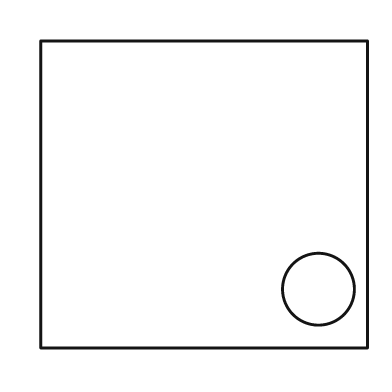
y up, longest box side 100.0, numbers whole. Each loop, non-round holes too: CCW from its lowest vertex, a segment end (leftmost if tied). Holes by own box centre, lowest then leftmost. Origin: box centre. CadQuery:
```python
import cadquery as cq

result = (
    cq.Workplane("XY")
    .moveTo(-50.0, -47.0)
    .lineTo(50.0, -47.0)
    .lineTo(50.0, 47.0)
    .lineTo(-50.0, 47.0)
    .close()
    .moveTo(35.0, -29.0)
    .circle(11.0)
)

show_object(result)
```